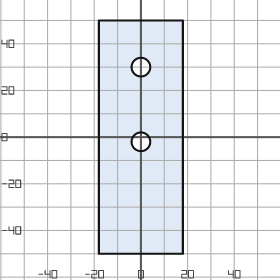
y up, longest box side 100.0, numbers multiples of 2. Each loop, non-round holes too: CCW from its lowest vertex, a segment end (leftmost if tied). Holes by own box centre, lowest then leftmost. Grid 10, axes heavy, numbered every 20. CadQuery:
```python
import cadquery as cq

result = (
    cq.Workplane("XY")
    .moveTo(-18.0, -50.0)
    .lineTo(18.0, -50.0)
    .lineTo(18.0, 50.0)
    .lineTo(-18.0, 50.0)
    .close()
    .moveTo(0.0, -2.0)
    .circle(4.0)
    .moveTo(0.0, 30.0)
    .circle(4.0)
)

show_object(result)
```